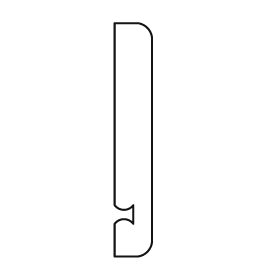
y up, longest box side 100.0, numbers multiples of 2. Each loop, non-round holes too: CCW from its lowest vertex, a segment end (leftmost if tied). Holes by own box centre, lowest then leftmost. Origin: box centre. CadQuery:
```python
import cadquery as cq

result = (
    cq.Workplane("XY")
    .moveTo(-8.0, -50.0)
    .lineTo(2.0, -50.0)
    .threePointArc((6.0, -48.0), (8.0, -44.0))
    .lineTo(8.0, 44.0)
    .threePointArc((6.0, 48.0), (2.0, 50.0))
    .lineTo(-8.0, 50.0)
    .lineTo(-8.0, -28.0)
    .threePointArc((-4.0, -30.0), (0.0, -28.0))
    .lineTo(0.0, -36.0)
    .threePointArc((-4.0, -34.0), (-8.0, -36.0))
    .close()
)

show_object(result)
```